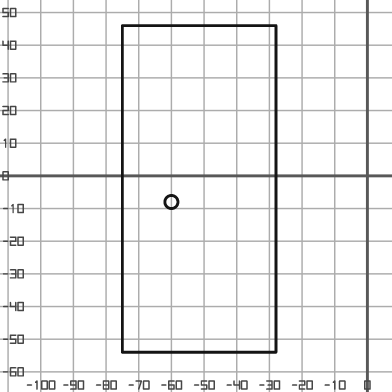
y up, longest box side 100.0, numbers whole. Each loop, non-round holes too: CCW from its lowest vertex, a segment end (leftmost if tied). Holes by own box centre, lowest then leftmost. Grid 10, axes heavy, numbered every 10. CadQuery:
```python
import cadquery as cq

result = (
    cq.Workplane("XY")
    .moveTo(-75.0, -54.0)
    .lineTo(-28.0, -54.0)
    .lineTo(-28.0, 46.0)
    .lineTo(-75.0, 46.0)
    .close()
    .moveTo(-60.0, -8.0)
    .circle(2.0)
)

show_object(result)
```